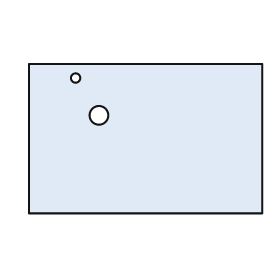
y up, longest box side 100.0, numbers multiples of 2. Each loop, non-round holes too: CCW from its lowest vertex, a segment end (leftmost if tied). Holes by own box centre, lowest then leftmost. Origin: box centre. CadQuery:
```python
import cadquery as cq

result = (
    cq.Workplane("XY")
    .moveTo(-50.0, -32.0)
    .lineTo(50.0, -32.0)
    .lineTo(50.0, 32.0)
    .lineTo(-50.0, 32.0)
    .close()
    .moveTo(-20.0, 10.0)
    .circle(4.0)
    .moveTo(-30.0, 26.0)
    .circle(2.0)
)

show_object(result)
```